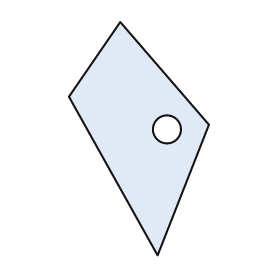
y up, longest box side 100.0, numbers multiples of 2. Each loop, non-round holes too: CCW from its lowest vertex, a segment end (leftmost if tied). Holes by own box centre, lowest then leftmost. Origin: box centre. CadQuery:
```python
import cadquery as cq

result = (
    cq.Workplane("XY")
    .moveTo(8.0, -50.0)
    .lineTo(30.0, 6.0)
    .lineTo(-8.0, 50.0)
    .lineTo(-30.0, 18.0)
    .close()
    .moveTo(12.0, 4.0)
    .circle(6.0)
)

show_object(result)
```